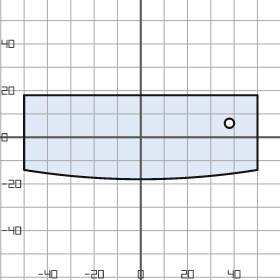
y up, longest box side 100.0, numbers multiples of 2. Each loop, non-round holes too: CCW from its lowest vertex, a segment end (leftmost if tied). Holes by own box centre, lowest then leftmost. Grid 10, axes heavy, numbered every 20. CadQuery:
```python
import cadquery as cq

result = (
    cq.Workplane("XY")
    .moveTo(-50.0, -14.0)
    .threePointArc((0.0, -18.0), (50.0, -14.0))
    .lineTo(50.0, 18.0)
    .lineTo(-50.0, 18.0)
    .close()
    .moveTo(38.0, 6.0)
    .circle(2.0)
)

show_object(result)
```